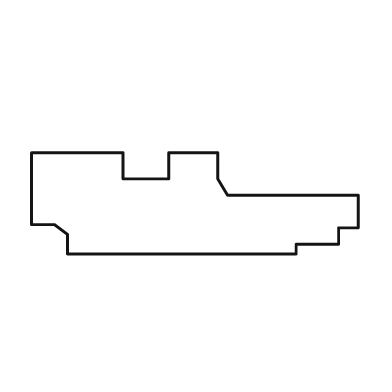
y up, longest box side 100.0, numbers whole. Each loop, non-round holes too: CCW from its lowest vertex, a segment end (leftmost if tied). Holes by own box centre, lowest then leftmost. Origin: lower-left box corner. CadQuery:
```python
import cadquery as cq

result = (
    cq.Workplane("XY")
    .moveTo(11.0, 0.0)
    .lineTo(81.0, 0.0)
    .lineTo(81.0, 3.0)
    .lineTo(94.0, 3.0)
    .lineTo(94.0, 8.0)
    .lineTo(100.0, 8.0)
    .lineTo(100.0, 18.0)
    .lineTo(60.0, 18.0)
    .lineTo(57.0, 23.0)
    .lineTo(57.0, 31.0)
    .lineTo(42.0, 31.0)
    .lineTo(42.0, 23.0)
    .lineTo(28.0, 23.0)
    .lineTo(28.0, 31.0)
    .lineTo(0.0, 31.0)
    .lineTo(0.0, 9.0)
    .lineTo(7.0, 9.0)
    .lineTo(11.0, 6.0)
    .close()
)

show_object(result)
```